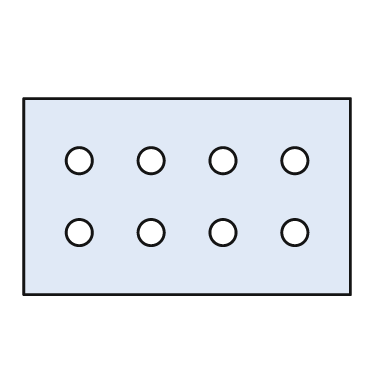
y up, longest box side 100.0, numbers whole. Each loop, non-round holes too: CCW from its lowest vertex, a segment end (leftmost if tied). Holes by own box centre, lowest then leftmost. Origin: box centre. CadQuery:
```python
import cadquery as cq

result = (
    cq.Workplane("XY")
    .moveTo(-50.0, -30.0)
    .lineTo(50.0, -30.0)
    .lineTo(50.0, 30.0)
    .lineTo(-50.0, 30.0)
    .close()
    .moveTo(-33.0, -11.0)
    .circle(4.0)
    .moveTo(-11.0, -11.0)
    .circle(4.0)
    .moveTo(11.0, -11.0)
    .circle(4.0)
    .moveTo(33.0, -11.0)
    .circle(4.0)
    .moveTo(-33.0, 11.0)
    .circle(4.0)
    .moveTo(-11.0, 11.0)
    .circle(4.0)
    .moveTo(11.0, 11.0)
    .circle(4.0)
    .moveTo(33.0, 11.0)
    .circle(4.0)
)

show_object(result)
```